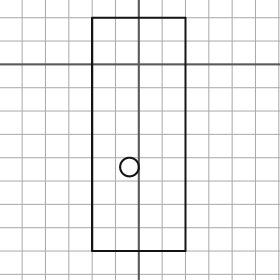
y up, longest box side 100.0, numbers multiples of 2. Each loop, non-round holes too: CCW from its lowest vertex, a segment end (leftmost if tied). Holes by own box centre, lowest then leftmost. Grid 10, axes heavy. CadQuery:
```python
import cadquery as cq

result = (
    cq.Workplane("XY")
    .moveTo(-20.0, -80.0)
    .lineTo(20.0, -80.0)
    .lineTo(20.0, 20.0)
    .lineTo(-20.0, 20.0)
    .close()
    .moveTo(-4.0, -44.0)
    .circle(4.0)
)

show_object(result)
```